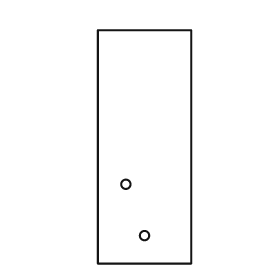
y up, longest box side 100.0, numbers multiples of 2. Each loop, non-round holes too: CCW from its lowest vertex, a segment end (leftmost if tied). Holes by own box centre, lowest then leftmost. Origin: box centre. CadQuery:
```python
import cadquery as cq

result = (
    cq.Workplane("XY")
    .moveTo(-20.0, -50.0)
    .lineTo(20.0, -50.0)
    .lineTo(20.0, 50.0)
    .lineTo(-20.0, 50.0)
    .close()
    .moveTo(0.0, -38.0)
    .circle(2.0)
    .moveTo(-8.0, -16.0)
    .circle(2.0)
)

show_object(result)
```